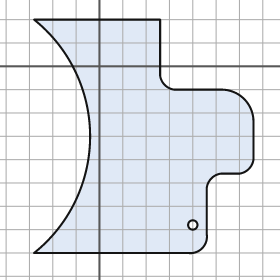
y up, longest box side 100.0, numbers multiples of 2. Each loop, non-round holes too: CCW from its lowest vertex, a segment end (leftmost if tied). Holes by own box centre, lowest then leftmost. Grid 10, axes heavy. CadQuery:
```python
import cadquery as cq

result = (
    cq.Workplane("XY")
    .moveTo(-28.0, -80.0)
    .lineTo(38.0, -80.0)
    .threePointArc((44.0, -78.0), (46.0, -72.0))
    .lineTo(46.0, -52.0)
    .threePointArc((48.0, -48.0), (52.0, -46.0))
    .lineTo(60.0, -46.0)
    .threePointArc((64.0, -44.0), (66.0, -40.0))
    .lineTo(66.0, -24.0)
    .threePointArc((62.0, -14.0), (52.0, -10.0))
    .lineTo(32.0, -10.0)
    .threePointArc((28.0, -8.0), (26.0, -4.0))
    .lineTo(26.0, 20.0)
    .lineTo(-28.0, 20.0)
    .threePointArc((-4.0, -30.0), (-28.0, -80.0))
    .close()
    .moveTo(40.0, -68.0)
    .circle(2.0)
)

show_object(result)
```